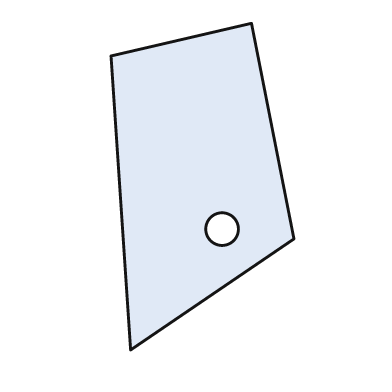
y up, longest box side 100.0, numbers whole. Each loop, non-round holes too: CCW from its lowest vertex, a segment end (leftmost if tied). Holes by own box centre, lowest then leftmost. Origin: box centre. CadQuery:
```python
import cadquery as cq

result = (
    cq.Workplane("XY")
    .moveTo(-22.0, -50.0)
    .lineTo(28.0, -16.0)
    .lineTo(15.0, 50.0)
    .lineTo(-28.0, 40.0)
    .close()
    .moveTo(6.0, -13.0)
    .circle(5.0)
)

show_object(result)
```